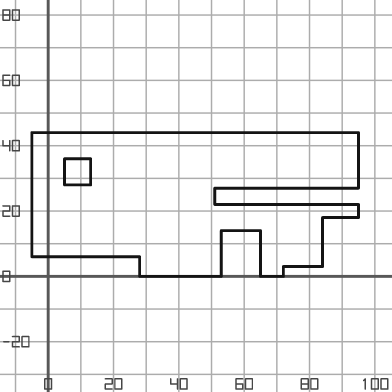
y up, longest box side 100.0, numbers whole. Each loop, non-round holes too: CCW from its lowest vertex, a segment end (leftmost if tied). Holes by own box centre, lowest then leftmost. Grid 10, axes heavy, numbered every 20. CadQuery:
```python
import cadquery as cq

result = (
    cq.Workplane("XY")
    .moveTo(28.0, 0.0)
    .lineTo(53.0, 0.0)
    .lineTo(53.0, 14.0)
    .lineTo(65.0, 14.0)
    .lineTo(65.0, 0.0)
    .lineTo(72.0, 0.0)
    .lineTo(72.0, 3.0)
    .lineTo(84.0, 3.0)
    .lineTo(84.0, 18.0)
    .lineTo(95.0, 18.0)
    .lineTo(95.0, 22.0)
    .lineTo(51.0, 22.0)
    .lineTo(51.0, 27.0)
    .lineTo(95.0, 27.0)
    .lineTo(95.0, 44.0)
    .lineTo(-5.0, 44.0)
    .lineTo(-5.0, 6.0)
    .lineTo(28.0, 6.0)
    .close()
    .moveTo(5.0, 28.0)
    .lineTo(13.0, 28.0)
    .lineTo(13.0, 36.0)
    .lineTo(5.0, 36.0)
    .close()
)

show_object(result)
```